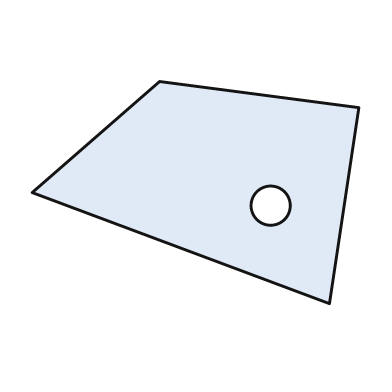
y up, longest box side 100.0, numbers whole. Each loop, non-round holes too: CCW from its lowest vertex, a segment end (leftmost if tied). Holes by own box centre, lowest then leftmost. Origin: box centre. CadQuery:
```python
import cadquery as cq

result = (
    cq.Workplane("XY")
    .moveTo(41.0, -34.0)
    .lineTo(50.0, 26.0)
    .lineTo(-11.0, 34.0)
    .lineTo(-50.0, 0.0)
    .close()
    .moveTo(23.0, -4.0)
    .circle(6.0)
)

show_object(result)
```